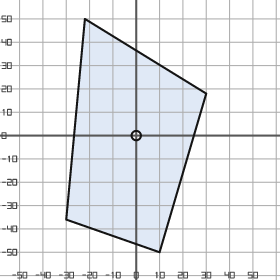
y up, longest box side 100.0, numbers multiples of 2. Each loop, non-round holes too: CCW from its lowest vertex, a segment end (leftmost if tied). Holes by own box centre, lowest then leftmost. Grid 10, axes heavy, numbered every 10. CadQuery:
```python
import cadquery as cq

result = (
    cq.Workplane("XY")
    .moveTo(10.0, -50.0)
    .lineTo(30.0, 18.0)
    .lineTo(-22.0, 50.0)
    .lineTo(-30.0, -36.0)
    .close()
    .moveTo(0.0, 0.0)
    .circle(2.0)
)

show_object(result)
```